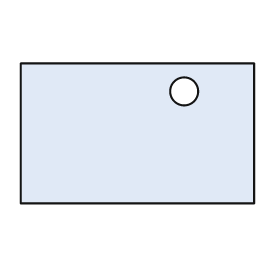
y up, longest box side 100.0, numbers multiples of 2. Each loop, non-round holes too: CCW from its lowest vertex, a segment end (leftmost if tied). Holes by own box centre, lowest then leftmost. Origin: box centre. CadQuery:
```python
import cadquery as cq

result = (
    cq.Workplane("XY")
    .moveTo(-50.0, -30.0)
    .lineTo(50.0, -30.0)
    .lineTo(50.0, 30.0)
    .lineTo(-50.0, 30.0)
    .close()
    .moveTo(20.0, 18.0)
    .circle(6.0)
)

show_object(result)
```